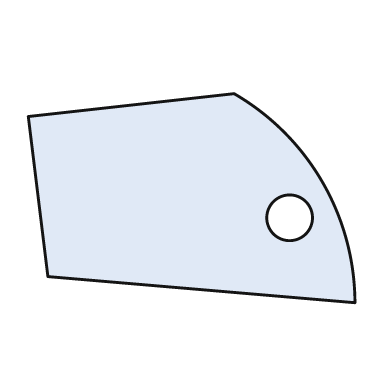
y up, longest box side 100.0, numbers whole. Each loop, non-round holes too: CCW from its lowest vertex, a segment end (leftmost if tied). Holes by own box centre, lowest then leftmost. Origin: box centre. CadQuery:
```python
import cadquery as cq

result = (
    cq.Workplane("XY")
    .moveTo(50.0, -32.0)
    .threePointArc((40.0, 5.0), (13.0, 32.0))
    .lineTo(-50.0, 25.0)
    .lineTo(-44.0, -24.0)
    .close()
    .moveTo(30.0, -6.0)
    .circle(7.0)
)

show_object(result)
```